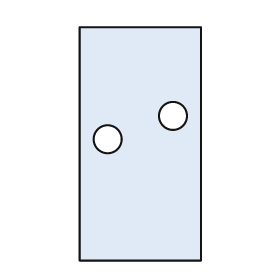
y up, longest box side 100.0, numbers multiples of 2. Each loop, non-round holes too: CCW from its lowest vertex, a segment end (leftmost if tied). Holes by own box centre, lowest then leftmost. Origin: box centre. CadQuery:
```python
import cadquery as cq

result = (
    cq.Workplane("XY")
    .moveTo(-26.0, -50.0)
    .lineTo(26.0, -50.0)
    .lineTo(26.0, 50.0)
    .lineTo(-26.0, 50.0)
    .close()
    .moveTo(-14.0, 2.0)
    .circle(6.0)
    .moveTo(14.0, 12.0)
    .circle(6.0)
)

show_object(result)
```